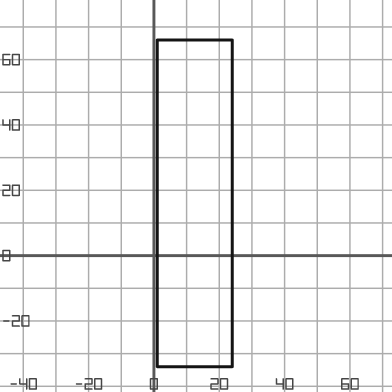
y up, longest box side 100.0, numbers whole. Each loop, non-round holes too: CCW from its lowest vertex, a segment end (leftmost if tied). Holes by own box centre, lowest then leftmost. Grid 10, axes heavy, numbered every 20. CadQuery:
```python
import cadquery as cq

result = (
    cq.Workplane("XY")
    .moveTo(1.0, -34.0)
    .lineTo(24.0, -34.0)
    .lineTo(24.0, 66.0)
    .lineTo(1.0, 66.0)
    .close()
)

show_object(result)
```